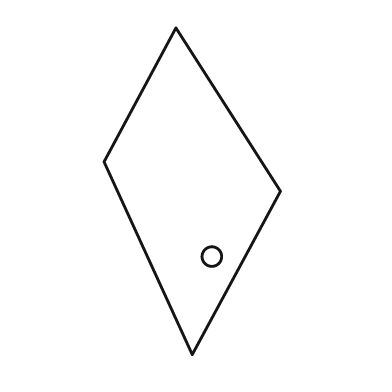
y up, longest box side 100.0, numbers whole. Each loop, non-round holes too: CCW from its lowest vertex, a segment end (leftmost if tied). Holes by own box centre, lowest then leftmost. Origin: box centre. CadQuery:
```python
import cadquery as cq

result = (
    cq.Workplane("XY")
    .moveTo(0.0, -50.0)
    .lineTo(27.0, 0.0)
    .lineTo(-5.0, 50.0)
    .lineTo(-27.0, 9.0)
    .close()
    .moveTo(6.0, -20.0)
    .circle(3.0)
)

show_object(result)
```